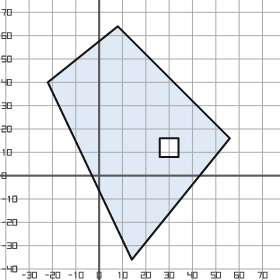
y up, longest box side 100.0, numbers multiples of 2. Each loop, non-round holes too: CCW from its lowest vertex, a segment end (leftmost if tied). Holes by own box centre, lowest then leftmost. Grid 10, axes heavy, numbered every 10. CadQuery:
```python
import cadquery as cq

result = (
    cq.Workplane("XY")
    .moveTo(14.0, -36.0)
    .lineTo(56.0, 16.0)
    .lineTo(8.0, 64.0)
    .lineTo(-22.0, 40.0)
    .close()
    .moveTo(26.0, 8.0)
    .lineTo(34.0, 8.0)
    .lineTo(34.0, 16.0)
    .lineTo(26.0, 16.0)
    .close()
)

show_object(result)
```